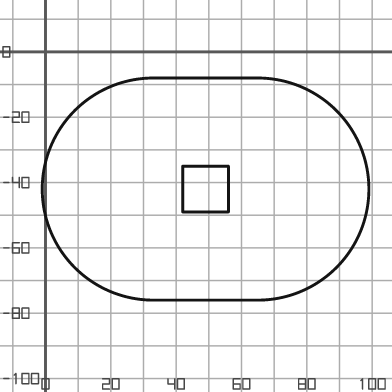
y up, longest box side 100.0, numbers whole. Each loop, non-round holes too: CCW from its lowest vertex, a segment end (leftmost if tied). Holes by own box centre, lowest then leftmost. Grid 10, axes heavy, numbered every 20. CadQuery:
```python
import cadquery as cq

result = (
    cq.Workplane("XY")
    .moveTo(33.0, -76.0)
    .lineTo(65.0, -76.0)
    .threePointArc((99.0, -42.0), (65.0, -8.0))
    .lineTo(33.0, -8.0)
    .threePointArc((-1.0, -42.0), (33.0, -76.0))
    .close()
    .moveTo(42.0, -49.0)
    .lineTo(56.0, -49.0)
    .lineTo(56.0, -35.0)
    .lineTo(42.0, -35.0)
    .close()
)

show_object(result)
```